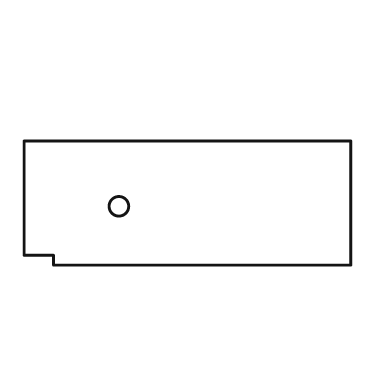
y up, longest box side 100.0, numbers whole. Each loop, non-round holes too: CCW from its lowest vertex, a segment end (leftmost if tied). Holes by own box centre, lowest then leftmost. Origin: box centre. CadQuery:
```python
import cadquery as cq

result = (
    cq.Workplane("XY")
    .moveTo(-41.0, -19.0)
    .lineTo(50.0, -19.0)
    .lineTo(50.0, 19.0)
    .lineTo(-50.0, 19.0)
    .lineTo(-50.0, -16.0)
    .lineTo(-41.0, -16.0)
    .close()
    .moveTo(-21.0, -1.0)
    .circle(3.0)
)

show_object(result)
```